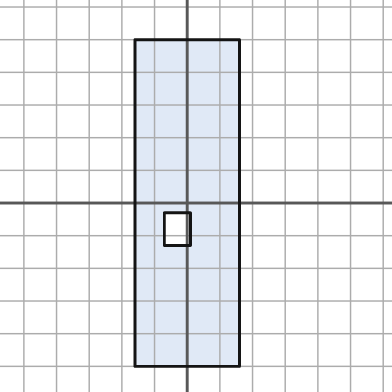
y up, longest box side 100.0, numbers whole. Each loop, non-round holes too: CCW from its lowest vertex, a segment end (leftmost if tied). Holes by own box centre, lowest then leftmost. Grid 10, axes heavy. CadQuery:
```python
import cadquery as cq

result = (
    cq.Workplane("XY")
    .moveTo(-16.0, -50.0)
    .lineTo(16.0, -50.0)
    .lineTo(16.0, 50.0)
    .lineTo(-16.0, 50.0)
    .close()
    .moveTo(-7.0, -13.0)
    .lineTo(1.0, -13.0)
    .lineTo(1.0, -3.0)
    .lineTo(-7.0, -3.0)
    .close()
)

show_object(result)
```